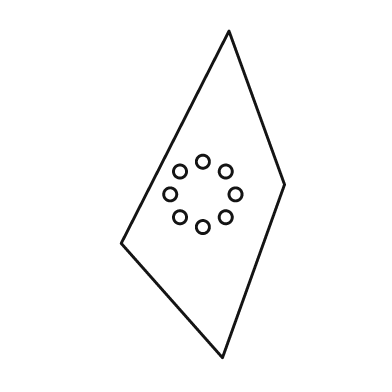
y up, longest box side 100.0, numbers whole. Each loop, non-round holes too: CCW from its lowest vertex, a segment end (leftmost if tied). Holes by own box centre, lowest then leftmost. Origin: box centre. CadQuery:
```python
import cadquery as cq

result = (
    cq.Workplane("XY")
    .moveTo(6.0, -50.0)
    .lineTo(25.0, 3.0)
    .lineTo(8.0, 50.0)
    .lineTo(-25.0, -15.0)
    .close()
    .moveTo(0.0, -10.0)
    .circle(2.0)
    .moveTo(-7.0, -7.0)
    .circle(2.0)
    .moveTo(7.0, -7.0)
    .circle(2.0)
    .moveTo(-10.0, 0.0)
    .circle(2.0)
    .moveTo(10.0, 0.0)
    .circle(2.0)
    .moveTo(-7.0, 7.0)
    .circle(2.0)
    .moveTo(7.0, 7.0)
    .circle(2.0)
    .moveTo(0.0, 10.0)
    .circle(2.0)
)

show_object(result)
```